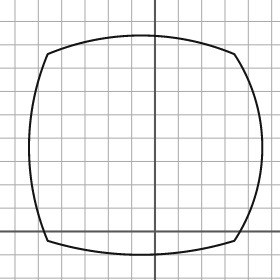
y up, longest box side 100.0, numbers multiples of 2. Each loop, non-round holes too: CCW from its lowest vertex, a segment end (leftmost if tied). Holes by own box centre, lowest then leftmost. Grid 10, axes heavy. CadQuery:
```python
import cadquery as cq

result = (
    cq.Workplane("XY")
    .moveTo(-46.0, -4.0)
    .threePointArc((-6.0, -10.0), (34.0, -4.0))
    .threePointArc((46.0, 36.0), (34.0, 76.0))
    .threePointArc((-6.0, 84.0), (-46.0, 76.0))
    .threePointArc((-54.0, 36.0), (-46.0, -4.0))
    .close()
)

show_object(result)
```